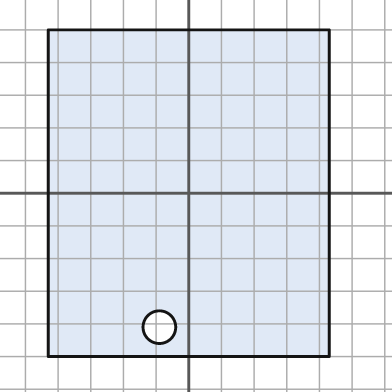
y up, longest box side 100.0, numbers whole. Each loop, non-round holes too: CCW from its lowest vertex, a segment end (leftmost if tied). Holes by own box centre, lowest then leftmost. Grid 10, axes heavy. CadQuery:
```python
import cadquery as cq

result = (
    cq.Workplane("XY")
    .moveTo(-43.0, -50.0)
    .lineTo(43.0, -50.0)
    .lineTo(43.0, 50.0)
    .lineTo(-43.0, 50.0)
    .close()
    .moveTo(-9.0, -41.0)
    .circle(5.0)
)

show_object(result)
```